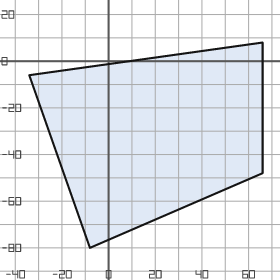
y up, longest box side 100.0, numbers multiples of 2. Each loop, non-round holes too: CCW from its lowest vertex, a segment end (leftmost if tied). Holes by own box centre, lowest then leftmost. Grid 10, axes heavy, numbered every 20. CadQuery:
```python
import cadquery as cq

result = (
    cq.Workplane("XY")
    .moveTo(-8.0, -80.0)
    .lineTo(66.0, -48.0)
    .lineTo(66.0, 8.0)
    .lineTo(-34.0, -6.0)
    .close()
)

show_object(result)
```